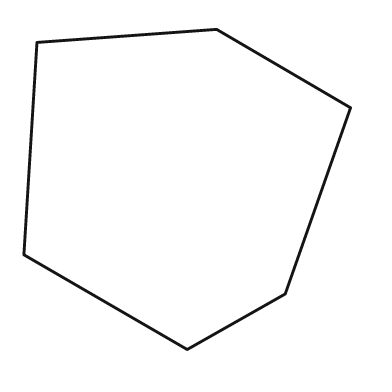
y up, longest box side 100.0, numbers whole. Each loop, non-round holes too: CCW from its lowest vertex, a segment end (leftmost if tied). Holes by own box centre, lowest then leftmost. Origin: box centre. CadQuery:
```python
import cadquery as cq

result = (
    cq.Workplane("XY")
    .moveTo(0.0, -49.0)
    .lineTo(30.0, -32.0)
    .lineTo(50.0, 25.0)
    .lineTo(9.0, 49.0)
    .lineTo(-46.0, 45.0)
    .lineTo(-50.0, -20.0)
    .close()
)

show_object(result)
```